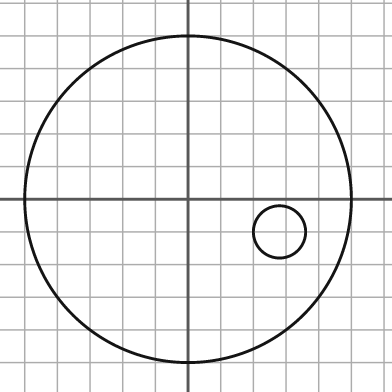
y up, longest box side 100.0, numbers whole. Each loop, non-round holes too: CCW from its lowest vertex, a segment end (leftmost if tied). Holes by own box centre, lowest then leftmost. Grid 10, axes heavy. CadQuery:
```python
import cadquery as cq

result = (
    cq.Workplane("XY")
    .moveTo(0.0, 0.0)
    .circle(50.0)
    .moveTo(28.0, -10.0)
    .circle(8.0)
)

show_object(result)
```